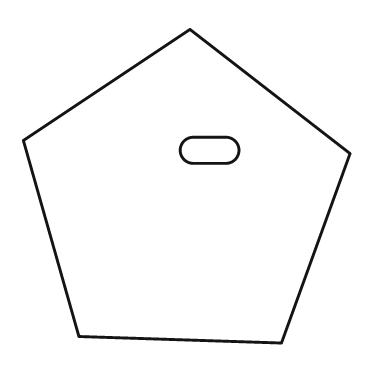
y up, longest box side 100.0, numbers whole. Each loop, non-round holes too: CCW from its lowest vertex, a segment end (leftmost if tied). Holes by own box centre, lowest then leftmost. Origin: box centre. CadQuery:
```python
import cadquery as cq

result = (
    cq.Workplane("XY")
    .moveTo(29.0, -48.0)
    .lineTo(50.0, 10.0)
    .lineTo(1.0, 48.0)
    .lineTo(-50.0, 14.0)
    .lineTo(-33.0, -46.0)
    .close()
    .moveTo(2.0, 7.0)
    .lineTo(12.0, 7.0)
    .threePointArc((16.0, 11.0), (12.0, 15.0))
    .lineTo(2.0, 15.0)
    .threePointArc((-2.0, 11.0), (2.0, 7.0))
    .close()
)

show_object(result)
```